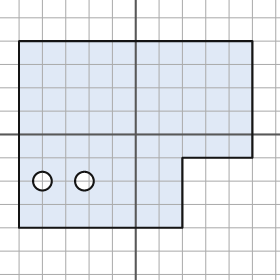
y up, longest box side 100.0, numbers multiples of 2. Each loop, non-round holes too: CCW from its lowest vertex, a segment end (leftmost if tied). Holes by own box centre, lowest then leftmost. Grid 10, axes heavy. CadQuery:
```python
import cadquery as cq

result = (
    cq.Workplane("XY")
    .moveTo(-50.0, -40.0)
    .lineTo(20.0, -40.0)
    .lineTo(20.0, -10.0)
    .lineTo(50.0, -10.0)
    .lineTo(50.0, 40.0)
    .lineTo(-50.0, 40.0)
    .close()
    .moveTo(-40.0, -20.0)
    .circle(4.0)
    .moveTo(-22.0, -20.0)
    .circle(4.0)
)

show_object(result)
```